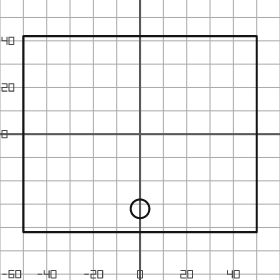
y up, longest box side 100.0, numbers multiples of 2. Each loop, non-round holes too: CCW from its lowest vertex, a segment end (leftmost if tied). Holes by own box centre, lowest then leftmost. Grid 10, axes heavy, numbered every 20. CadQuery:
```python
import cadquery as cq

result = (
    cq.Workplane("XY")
    .moveTo(-50.0, -42.0)
    .lineTo(50.0, -42.0)
    .lineTo(50.0, 42.0)
    .lineTo(-50.0, 42.0)
    .close()
    .moveTo(0.0, -32.0)
    .circle(4.0)
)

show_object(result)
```